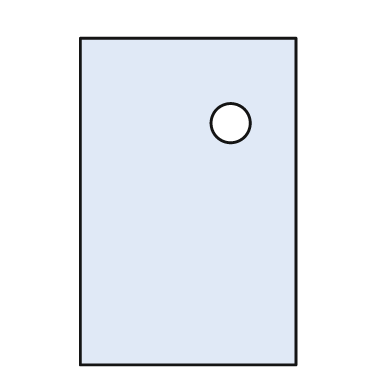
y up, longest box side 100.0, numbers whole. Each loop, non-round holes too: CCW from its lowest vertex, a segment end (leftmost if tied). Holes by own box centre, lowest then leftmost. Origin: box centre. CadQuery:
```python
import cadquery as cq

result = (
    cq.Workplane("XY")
    .moveTo(-33.0, -50.0)
    .lineTo(33.0, -50.0)
    .lineTo(33.0, 50.0)
    .lineTo(-33.0, 50.0)
    .close()
    .moveTo(13.0, 24.0)
    .circle(6.0)
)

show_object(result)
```